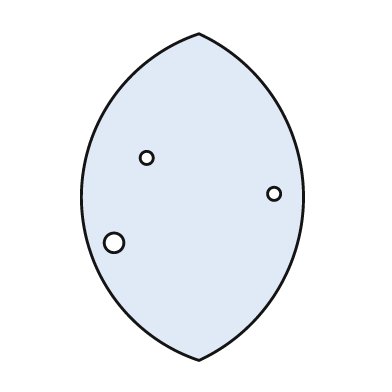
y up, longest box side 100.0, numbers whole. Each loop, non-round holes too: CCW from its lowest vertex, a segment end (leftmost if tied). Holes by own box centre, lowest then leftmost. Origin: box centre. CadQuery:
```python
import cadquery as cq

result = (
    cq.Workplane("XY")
    .moveTo(2.0, -50.0)
    .threePointArc((34.0, 0.0), (2.0, 50.0))
    .threePointArc((-34.0, 0.0), (2.0, -50.0))
    .close()
    .moveTo(-24.0, -14.0)
    .circle(3.0)
    .moveTo(25.0, 1.0)
    .circle(2.0)
    .moveTo(-14.0, 12.0)
    .circle(2.0)
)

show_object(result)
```